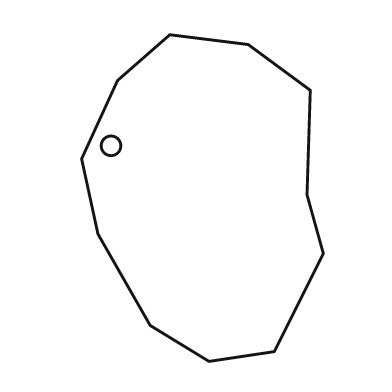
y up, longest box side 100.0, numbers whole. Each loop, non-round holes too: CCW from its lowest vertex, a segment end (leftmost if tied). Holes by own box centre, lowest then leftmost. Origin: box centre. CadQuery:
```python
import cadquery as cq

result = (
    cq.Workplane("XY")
    .moveTo(2.0, -50.0)
    .lineTo(22.0, -47.0)
    .lineTo(37.0, -17.0)
    .lineTo(32.0, 1.0)
    .lineTo(33.0, 33.0)
    .lineTo(14.0, 47.0)
    .lineTo(-10.0, 50.0)
    .lineTo(-26.0, 36.0)
    .lineTo(-37.0, 12.0)
    .lineTo(-32.0, -11.0)
    .lineTo(-16.0, -39.0)
    .close()
    .moveTo(-28.0, 16.0)
    .circle(3.0)
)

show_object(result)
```